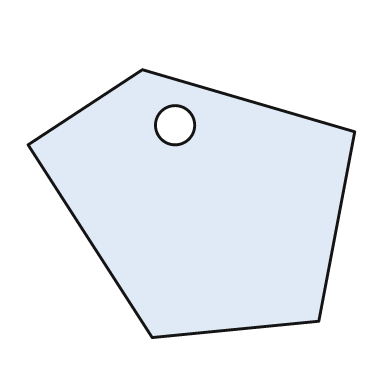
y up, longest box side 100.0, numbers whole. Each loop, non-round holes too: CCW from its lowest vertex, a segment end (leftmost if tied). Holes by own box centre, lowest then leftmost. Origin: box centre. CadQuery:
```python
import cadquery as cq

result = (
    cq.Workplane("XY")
    .moveTo(-12.0, -41.0)
    .lineTo(39.0, -36.0)
    .lineTo(50.0, 22.0)
    .lineTo(-15.0, 41.0)
    .lineTo(-50.0, 18.0)
    .close()
    .moveTo(-5.0, 24.0)
    .circle(6.0)
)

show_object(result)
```